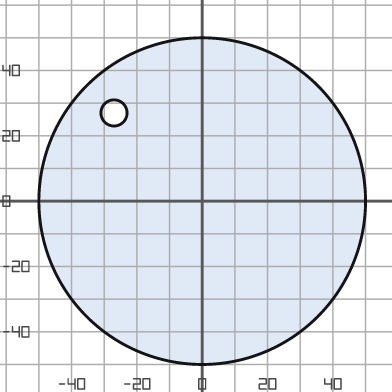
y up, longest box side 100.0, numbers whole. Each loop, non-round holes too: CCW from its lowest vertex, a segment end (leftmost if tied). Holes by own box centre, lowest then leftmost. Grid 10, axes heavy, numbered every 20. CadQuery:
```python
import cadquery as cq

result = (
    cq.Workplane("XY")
    .moveTo(0.0, 0.0)
    .circle(50.0)
    .moveTo(-27.0, 27.0)
    .circle(4.0)
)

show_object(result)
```